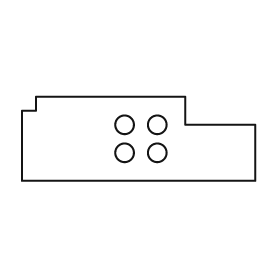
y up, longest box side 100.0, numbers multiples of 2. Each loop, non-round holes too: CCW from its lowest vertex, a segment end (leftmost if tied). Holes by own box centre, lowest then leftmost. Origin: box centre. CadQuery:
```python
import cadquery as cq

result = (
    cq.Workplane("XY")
    .moveTo(-50.0, -18.0)
    .lineTo(50.0, -18.0)
    .lineTo(50.0, 6.0)
    .lineTo(20.0, 6.0)
    .lineTo(20.0, 18.0)
    .lineTo(-44.0, 18.0)
    .lineTo(-44.0, 12.0)
    .lineTo(-50.0, 12.0)
    .close()
    .moveTo(-6.0, -6.0)
    .circle(4.0)
    .moveTo(8.0, -6.0)
    .circle(4.0)
    .moveTo(-6.0, 6.0)
    .circle(4.0)
    .moveTo(8.0, 6.0)
    .circle(4.0)
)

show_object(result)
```